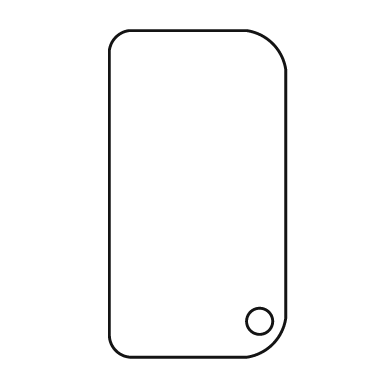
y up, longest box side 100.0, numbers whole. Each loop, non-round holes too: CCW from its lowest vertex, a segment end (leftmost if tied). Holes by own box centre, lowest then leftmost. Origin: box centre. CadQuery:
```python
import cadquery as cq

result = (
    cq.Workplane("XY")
    .moveTo(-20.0, -50.0)
    .lineTo(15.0, -50.0)
    .threePointArc((23.0, -46.0), (27.0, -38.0))
    .lineTo(27.0, 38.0)
    .threePointArc((23.0, 46.0), (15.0, 50.0))
    .lineTo(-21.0, 50.0)
    .threePointArc((-25.0, 48.0), (-27.0, 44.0))
    .lineTo(-27.0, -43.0)
    .threePointArc((-25.0, -48.0), (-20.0, -50.0))
    .close()
    .moveTo(19.0, -39.0)
    .circle(4.0)
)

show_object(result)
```